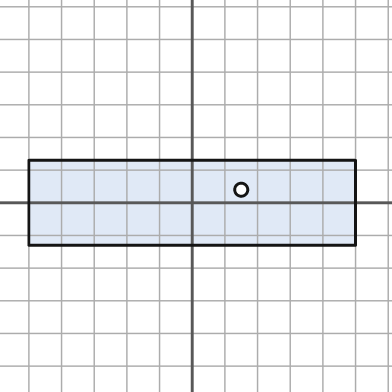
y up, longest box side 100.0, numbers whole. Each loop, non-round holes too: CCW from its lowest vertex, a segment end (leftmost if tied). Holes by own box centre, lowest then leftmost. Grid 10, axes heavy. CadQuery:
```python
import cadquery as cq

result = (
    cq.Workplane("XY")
    .moveTo(-50.0, -13.0)
    .lineTo(50.0, -13.0)
    .lineTo(50.0, 13.0)
    .lineTo(-50.0, 13.0)
    .close()
    .moveTo(15.0, 4.0)
    .circle(2.0)
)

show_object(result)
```